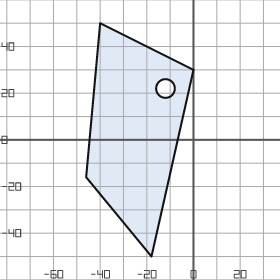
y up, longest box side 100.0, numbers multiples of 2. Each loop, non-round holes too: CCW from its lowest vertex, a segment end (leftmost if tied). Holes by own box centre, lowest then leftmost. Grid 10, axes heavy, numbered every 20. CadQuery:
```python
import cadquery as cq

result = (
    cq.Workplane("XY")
    .moveTo(-18.0, -50.0)
    .lineTo(0.0, 30.0)
    .lineTo(-40.0, 50.0)
    .lineTo(-46.0, -16.0)
    .close()
    .moveTo(-12.0, 22.0)
    .circle(4.0)
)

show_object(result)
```